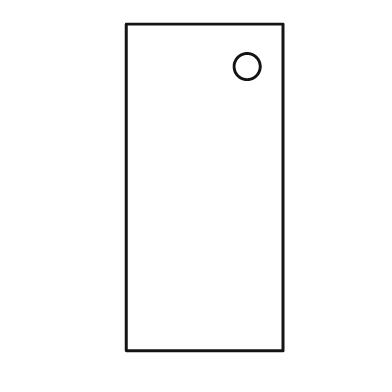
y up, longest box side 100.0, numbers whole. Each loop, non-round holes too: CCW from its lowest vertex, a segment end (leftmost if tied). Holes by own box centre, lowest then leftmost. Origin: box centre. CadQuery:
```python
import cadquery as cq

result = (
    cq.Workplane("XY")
    .moveTo(-24.0, -50.0)
    .lineTo(24.0, -50.0)
    .lineTo(24.0, 50.0)
    .lineTo(-24.0, 50.0)
    .close()
    .moveTo(13.0, 37.0)
    .circle(4.0)
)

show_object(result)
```